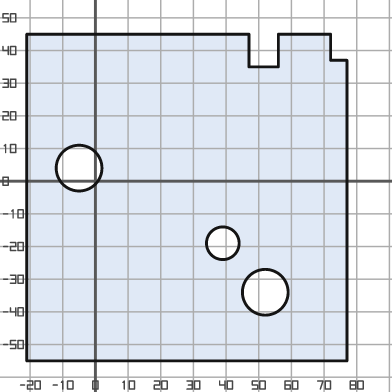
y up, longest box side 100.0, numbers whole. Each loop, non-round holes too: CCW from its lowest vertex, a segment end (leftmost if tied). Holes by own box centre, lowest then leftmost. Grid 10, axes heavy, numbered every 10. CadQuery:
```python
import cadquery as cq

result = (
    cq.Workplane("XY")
    .moveTo(-21.0, -55.0)
    .lineTo(77.0, -55.0)
    .lineTo(77.0, 37.0)
    .lineTo(72.0, 37.0)
    .lineTo(72.0, 45.0)
    .lineTo(56.0, 45.0)
    .lineTo(56.0, 35.0)
    .lineTo(47.0, 35.0)
    .lineTo(47.0, 45.0)
    .lineTo(-21.0, 45.0)
    .close()
    .moveTo(52.0, -34.0)
    .circle(7.0)
    .moveTo(39.0, -19.0)
    .circle(5.0)
    .moveTo(-5.0, 4.0)
    .circle(7.0)
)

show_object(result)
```